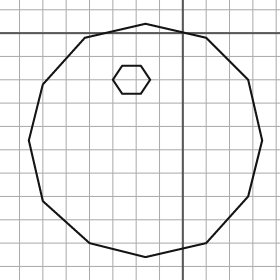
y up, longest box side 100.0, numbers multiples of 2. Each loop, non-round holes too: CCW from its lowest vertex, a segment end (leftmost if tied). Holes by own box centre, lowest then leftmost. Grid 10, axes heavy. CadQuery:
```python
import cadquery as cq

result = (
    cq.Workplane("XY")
    .moveTo(-16.0, -96.0)
    .lineTo(10.0, -90.0)
    .lineTo(28.0, -70.0)
    .lineTo(34.0, -46.0)
    .lineTo(28.0, -20.0)
    .lineTo(10.0, -2.0)
    .lineTo(-16.0, 4.0)
    .lineTo(-42.0, -2.0)
    .lineTo(-60.0, -22.0)
    .lineTo(-66.0, -46.0)
    .lineTo(-60.0, -72.0)
    .lineTo(-40.0, -90.0)
    .close()
    .moveTo(-26.0, -26.0)
    .lineTo(-18.0, -26.0)
    .lineTo(-14.0, -20.0)
    .lineTo(-18.0, -14.0)
    .lineTo(-26.0, -14.0)
    .lineTo(-30.0, -20.0)
    .close()
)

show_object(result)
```